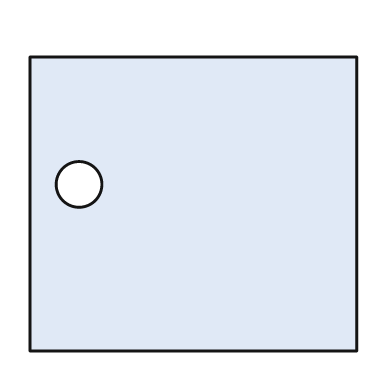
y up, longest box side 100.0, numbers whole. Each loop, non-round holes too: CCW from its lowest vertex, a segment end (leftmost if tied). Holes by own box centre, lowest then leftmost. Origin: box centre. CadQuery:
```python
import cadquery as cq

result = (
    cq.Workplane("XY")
    .moveTo(-50.0, -45.0)
    .lineTo(50.0, -45.0)
    .lineTo(50.0, 45.0)
    .lineTo(-50.0, 45.0)
    .close()
    .moveTo(-35.0, 6.0)
    .circle(7.0)
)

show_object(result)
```